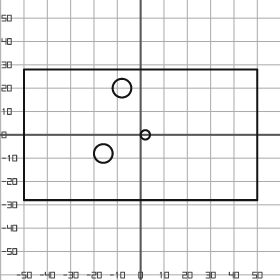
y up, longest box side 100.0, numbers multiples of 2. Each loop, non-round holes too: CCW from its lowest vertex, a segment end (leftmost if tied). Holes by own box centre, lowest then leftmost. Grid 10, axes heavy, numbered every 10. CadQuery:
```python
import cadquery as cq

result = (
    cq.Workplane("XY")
    .moveTo(-50.0, -28.0)
    .lineTo(50.0, -28.0)
    .lineTo(50.0, 28.0)
    .lineTo(-50.0, 28.0)
    .close()
    .moveTo(-16.0, -8.0)
    .circle(4.0)
    .moveTo(2.0, 0.0)
    .circle(2.0)
    .moveTo(-8.0, 20.0)
    .circle(4.0)
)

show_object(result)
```